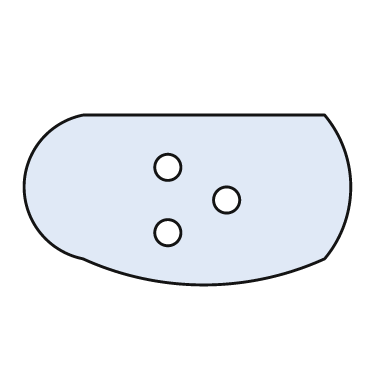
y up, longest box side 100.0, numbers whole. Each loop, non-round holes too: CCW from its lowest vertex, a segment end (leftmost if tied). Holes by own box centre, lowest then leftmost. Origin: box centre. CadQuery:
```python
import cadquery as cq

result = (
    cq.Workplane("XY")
    .moveTo(-32.0, -18.0)
    .threePointArc((5.0, -26.0), (42.0, -18.0))
    .threePointArc((50.0, 4.0), (42.0, 26.0))
    .lineTo(-32.0, 26.0)
    .threePointArc((-50.0, 4.0), (-32.0, -18.0))
    .close()
    .moveTo(-6.0, -10.0)
    .circle(4.0)
    .moveTo(12.0, 0.0)
    .circle(4.0)
    .moveTo(-6.0, 10.0)
    .circle(4.0)
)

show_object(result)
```